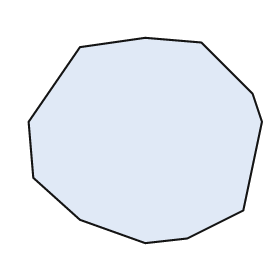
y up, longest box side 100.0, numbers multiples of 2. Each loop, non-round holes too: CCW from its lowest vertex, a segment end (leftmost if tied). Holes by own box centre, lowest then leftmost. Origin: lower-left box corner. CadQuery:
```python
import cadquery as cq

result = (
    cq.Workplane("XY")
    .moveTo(50.0, 0.0)
    .lineTo(68.0, 2.0)
    .lineTo(92.0, 14.0)
    .lineTo(100.0, 52.0)
    .lineTo(96.0, 64.0)
    .lineTo(74.0, 86.0)
    .lineTo(50.0, 88.0)
    .lineTo(22.0, 84.0)
    .lineTo(0.0, 52.0)
    .lineTo(2.0, 28.0)
    .lineTo(22.0, 10.0)
    .close()
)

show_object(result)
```